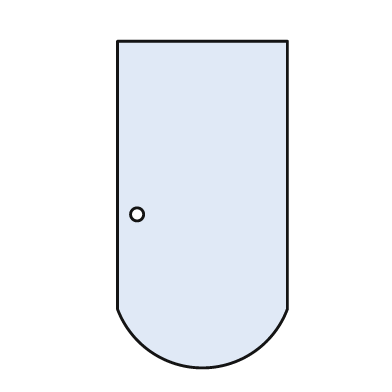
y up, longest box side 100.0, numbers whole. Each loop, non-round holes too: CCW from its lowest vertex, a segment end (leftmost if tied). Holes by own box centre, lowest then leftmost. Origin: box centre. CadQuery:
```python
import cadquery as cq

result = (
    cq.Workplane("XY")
    .moveTo(-26.0, -32.0)
    .threePointArc((0.0, -50.0), (26.0, -32.0))
    .lineTo(26.0, 50.0)
    .lineTo(-26.0, 50.0)
    .close()
    .moveTo(-20.0, -3.0)
    .circle(2.0)
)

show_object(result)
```